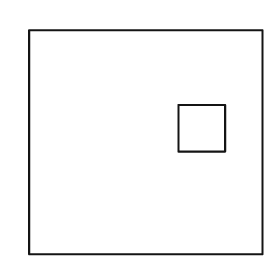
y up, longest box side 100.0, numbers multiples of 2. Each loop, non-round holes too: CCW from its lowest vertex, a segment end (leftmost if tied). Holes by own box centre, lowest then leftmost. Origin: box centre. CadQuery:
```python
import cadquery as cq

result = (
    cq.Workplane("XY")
    .moveTo(-50.0, -48.0)
    .lineTo(50.0, -48.0)
    .lineTo(50.0, 48.0)
    .lineTo(-50.0, 48.0)
    .close()
    .moveTo(14.0, -4.0)
    .lineTo(34.0, -4.0)
    .lineTo(34.0, 16.0)
    .lineTo(14.0, 16.0)
    .close()
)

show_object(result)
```